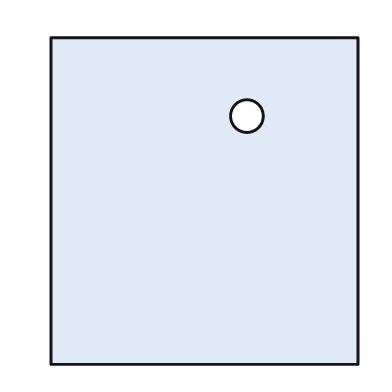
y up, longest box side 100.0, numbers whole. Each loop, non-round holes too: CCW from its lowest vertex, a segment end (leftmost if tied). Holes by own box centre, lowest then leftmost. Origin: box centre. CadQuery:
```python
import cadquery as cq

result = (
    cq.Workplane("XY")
    .moveTo(-47.0, -50.0)
    .lineTo(47.0, -50.0)
    .lineTo(47.0, 50.0)
    .lineTo(-47.0, 50.0)
    .close()
    .moveTo(13.0, 26.0)
    .circle(5.0)
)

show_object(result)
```